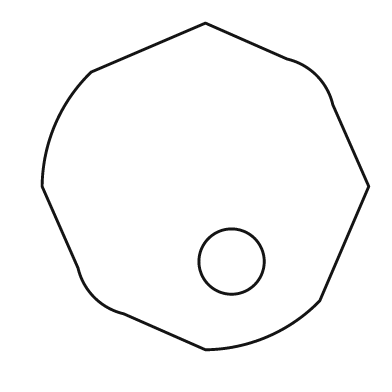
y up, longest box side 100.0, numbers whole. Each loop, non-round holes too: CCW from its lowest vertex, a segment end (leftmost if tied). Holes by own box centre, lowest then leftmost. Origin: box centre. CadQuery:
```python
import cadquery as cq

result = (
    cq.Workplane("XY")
    .moveTo(0.0, -50.0)
    .threePointArc((19.0, -46.0), (35.0, -35.0))
    .lineTo(50.0, 0.0)
    .lineTo(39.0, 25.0)
    .threePointArc((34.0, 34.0), (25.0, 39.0))
    .lineTo(0.0, 50.0)
    .lineTo(-35.0, 35.0)
    .threePointArc((-46.0, 19.0), (-50.0, 0.0))
    .lineTo(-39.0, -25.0)
    .threePointArc((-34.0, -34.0), (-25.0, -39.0))
    .close()
    .moveTo(8.0, -23.0)
    .circle(10.0)
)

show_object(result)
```